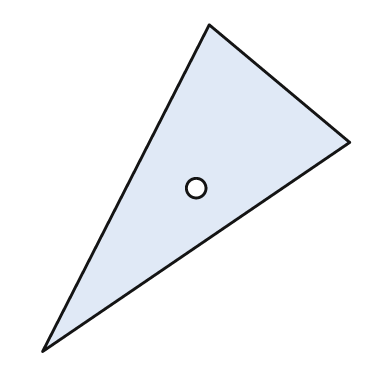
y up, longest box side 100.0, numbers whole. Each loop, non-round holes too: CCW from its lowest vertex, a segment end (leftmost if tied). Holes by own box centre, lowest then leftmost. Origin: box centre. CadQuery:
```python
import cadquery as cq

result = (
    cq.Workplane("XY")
    .moveTo(-47.0, -50.0)
    .lineTo(47.0, 14.0)
    .lineTo(4.0, 50.0)
    .close()
    .moveTo(0.0, 0.0)
    .circle(3.0)
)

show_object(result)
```